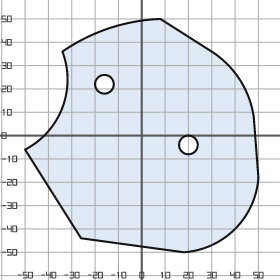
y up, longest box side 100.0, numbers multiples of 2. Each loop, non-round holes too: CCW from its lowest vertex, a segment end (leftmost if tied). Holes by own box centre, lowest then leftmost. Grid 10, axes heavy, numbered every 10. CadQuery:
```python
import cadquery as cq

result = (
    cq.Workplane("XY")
    .moveTo(18.0, -50.0)
    .threePointArc((40.0, -40.0), (50.0, -18.0))
    .lineTo(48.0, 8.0)
    .threePointArc((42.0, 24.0), (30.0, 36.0))
    .lineTo(8.0, 50.0)
    .threePointArc((-14.0, 46.0), (-34.0, 36.0))
    .threePointArc((-34.0, 12.0), (-50.0, -6.0))
    .lineTo(-26.0, -44.0)
    .close()
    .moveTo(20.0, -4.0)
    .circle(4.0)
    .moveTo(-16.0, 22.0)
    .circle(4.0)
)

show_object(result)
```